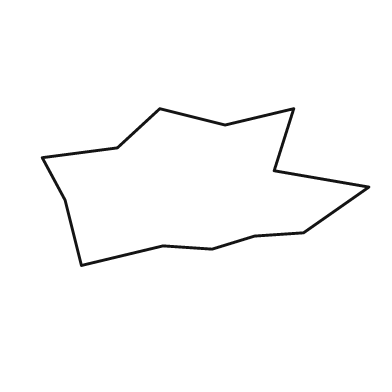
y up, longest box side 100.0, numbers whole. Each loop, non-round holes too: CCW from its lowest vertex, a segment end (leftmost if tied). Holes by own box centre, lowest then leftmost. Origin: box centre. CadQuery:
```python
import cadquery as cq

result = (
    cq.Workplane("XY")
    .moveTo(-38.0, -24.0)
    .lineTo(-13.0, -18.0)
    .lineTo(2.0, -19.0)
    .lineTo(15.0, -15.0)
    .lineTo(30.0, -14.0)
    .lineTo(50.0, 0.0)
    .lineTo(21.0, 5.0)
    .lineTo(27.0, 24.0)
    .lineTo(6.0, 19.0)
    .lineTo(-14.0, 24.0)
    .lineTo(-27.0, 12.0)
    .lineTo(-50.0, 9.0)
    .lineTo(-43.0, -4.0)
    .close()
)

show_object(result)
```